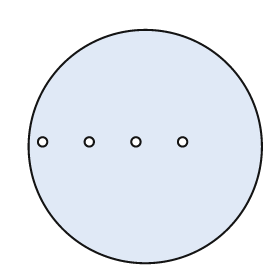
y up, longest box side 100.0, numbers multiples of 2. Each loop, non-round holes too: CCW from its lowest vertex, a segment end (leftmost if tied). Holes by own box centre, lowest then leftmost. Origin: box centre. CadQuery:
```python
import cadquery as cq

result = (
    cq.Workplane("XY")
    .moveTo(0.0, 0.0)
    .circle(50.0)
    .moveTo(-44.0, 2.0)
    .circle(2.0)
    .moveTo(-24.0, 2.0)
    .circle(2.0)
    .moveTo(-4.0, 2.0)
    .circle(2.0)
    .moveTo(16.0, 2.0)
    .circle(2.0)
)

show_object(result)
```